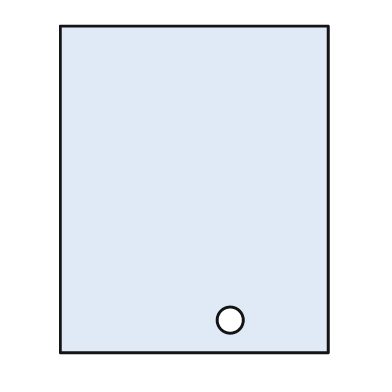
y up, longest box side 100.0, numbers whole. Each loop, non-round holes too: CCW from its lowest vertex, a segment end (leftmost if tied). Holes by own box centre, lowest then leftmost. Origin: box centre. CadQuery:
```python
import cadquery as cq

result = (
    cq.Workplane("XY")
    .moveTo(-41.0, -50.0)
    .lineTo(41.0, -50.0)
    .lineTo(41.0, 50.0)
    .lineTo(-41.0, 50.0)
    .close()
    .moveTo(11.0, -40.0)
    .circle(4.0)
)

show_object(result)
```